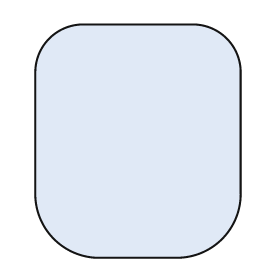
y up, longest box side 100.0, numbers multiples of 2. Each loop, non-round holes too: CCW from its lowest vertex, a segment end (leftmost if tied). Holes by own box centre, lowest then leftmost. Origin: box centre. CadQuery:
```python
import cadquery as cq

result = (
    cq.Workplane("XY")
    .moveTo(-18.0, -50.0)
    .lineTo(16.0, -50.0)
    .threePointArc((36.0, -42.0), (44.0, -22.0))
    .lineTo(44.0, 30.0)
    .threePointArc((38.0, 44.0), (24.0, 50.0))
    .lineTo(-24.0, 50.0)
    .threePointArc((-38.0, 44.0), (-44.0, 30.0))
    .lineTo(-44.0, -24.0)
    .threePointArc((-36.0, -42.0), (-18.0, -50.0))
    .close()
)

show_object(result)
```